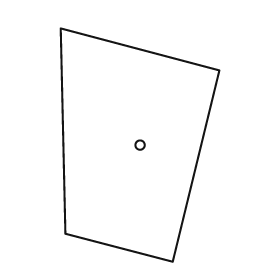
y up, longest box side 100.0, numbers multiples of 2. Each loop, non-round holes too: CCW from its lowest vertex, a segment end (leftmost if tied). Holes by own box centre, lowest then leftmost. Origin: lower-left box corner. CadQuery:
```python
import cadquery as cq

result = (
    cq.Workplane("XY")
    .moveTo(48.0, 0.0)
    .lineTo(68.0, 82.0)
    .lineTo(0.0, 100.0)
    .lineTo(2.0, 12.0)
    .close()
    .moveTo(34.0, 50.0)
    .circle(2.0)
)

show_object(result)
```